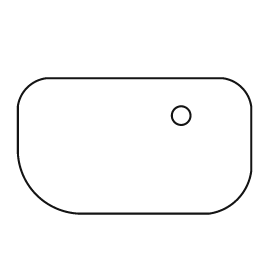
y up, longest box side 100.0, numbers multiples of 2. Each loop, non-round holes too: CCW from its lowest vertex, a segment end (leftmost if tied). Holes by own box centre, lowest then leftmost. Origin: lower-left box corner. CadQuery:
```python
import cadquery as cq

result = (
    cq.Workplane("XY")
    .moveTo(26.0, 0.0)
    .lineTo(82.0, 0.0)
    .threePointArc((94.0, 6.0), (100.0, 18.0))
    .lineTo(100.0, 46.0)
    .threePointArc((96.0, 54.0), (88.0, 58.0))
    .lineTo(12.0, 58.0)
    .threePointArc((4.0, 54.0), (0.0, 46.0))
    .lineTo(0.0, 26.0)
    .threePointArc((8.0, 8.0), (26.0, 0.0))
    .close()
    .moveTo(70.0, 42.0)
    .circle(4.0)
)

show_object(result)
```